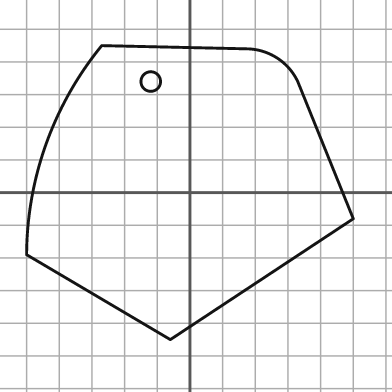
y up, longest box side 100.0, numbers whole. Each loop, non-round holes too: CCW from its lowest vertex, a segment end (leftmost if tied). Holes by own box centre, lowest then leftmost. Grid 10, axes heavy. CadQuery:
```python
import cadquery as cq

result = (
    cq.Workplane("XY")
    .moveTo(-6.0, -45.0)
    .lineTo(50.0, -8.0)
    .lineTo(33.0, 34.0)
    .threePointArc((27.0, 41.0), (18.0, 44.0))
    .lineTo(-27.0, 45.0)
    .threePointArc((-44.0, 15.0), (-50.0, -19.0))
    .close()
    .moveTo(-12.0, 34.0)
    .circle(3.0)
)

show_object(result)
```